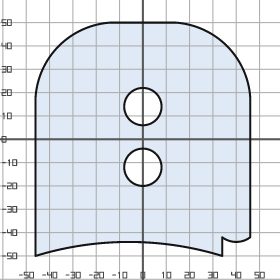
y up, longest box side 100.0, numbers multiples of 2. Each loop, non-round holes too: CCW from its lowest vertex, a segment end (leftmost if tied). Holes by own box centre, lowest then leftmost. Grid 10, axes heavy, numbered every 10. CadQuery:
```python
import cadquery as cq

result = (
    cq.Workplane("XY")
    .moveTo(-46.0, -50.0)
    .threePointArc((-6.0, -44.0), (34.0, -50.0))
    .lineTo(34.0, -42.0)
    .threePointArc((40.0, -44.0), (46.0, -42.0))
    .lineTo(46.0, 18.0)
    .threePointArc((36.0, 40.0), (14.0, 50.0))
    .lineTo(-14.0, 50.0)
    .threePointArc((-36.0, 40.0), (-46.0, 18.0))
    .close()
    .moveTo(0.0, -12.0)
    .circle(8.0)
    .moveTo(0.0, 14.0)
    .circle(8.0)
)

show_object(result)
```